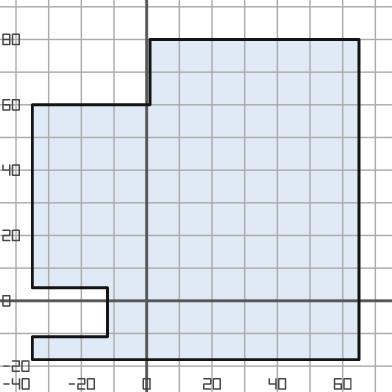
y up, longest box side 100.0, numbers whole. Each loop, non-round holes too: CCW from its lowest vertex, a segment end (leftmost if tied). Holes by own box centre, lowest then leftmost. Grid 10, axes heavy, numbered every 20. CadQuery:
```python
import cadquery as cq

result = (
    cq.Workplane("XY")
    .moveTo(-35.0, -18.0)
    .lineTo(65.0, -18.0)
    .lineTo(65.0, 80.0)
    .lineTo(1.0, 80.0)
    .lineTo(1.0, 60.0)
    .lineTo(-35.0, 60.0)
    .lineTo(-35.0, 4.0)
    .lineTo(-12.0, 4.0)
    .lineTo(-12.0, -11.0)
    .lineTo(-35.0, -11.0)
    .close()
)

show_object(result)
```